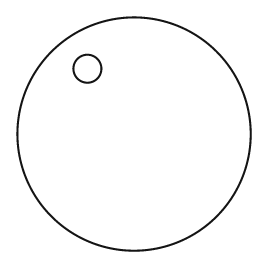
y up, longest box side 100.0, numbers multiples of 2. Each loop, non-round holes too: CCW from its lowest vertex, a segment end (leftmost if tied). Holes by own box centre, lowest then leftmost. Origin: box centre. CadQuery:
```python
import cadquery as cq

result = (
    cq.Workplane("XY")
    .moveTo(0.0, 0.0)
    .circle(50.0)
    .moveTo(-20.0, 28.0)
    .circle(6.0)
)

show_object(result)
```